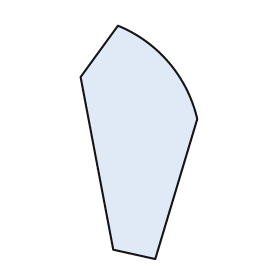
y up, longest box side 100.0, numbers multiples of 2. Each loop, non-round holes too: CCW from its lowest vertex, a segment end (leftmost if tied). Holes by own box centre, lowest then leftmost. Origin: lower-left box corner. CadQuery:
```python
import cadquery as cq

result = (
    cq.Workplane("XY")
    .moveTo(32.0, 0.0)
    .lineTo(50.0, 60.0)
    .threePointArc((38.0, 84.0), (16.0, 100.0))
    .lineTo(0.0, 78.0)
    .lineTo(14.0, 4.0)
    .close()
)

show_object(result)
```